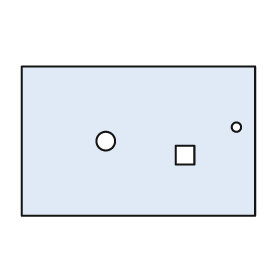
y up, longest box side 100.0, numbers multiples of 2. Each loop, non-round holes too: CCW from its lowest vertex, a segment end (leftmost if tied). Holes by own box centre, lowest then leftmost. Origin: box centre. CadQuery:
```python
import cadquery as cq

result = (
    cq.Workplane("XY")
    .moveTo(-50.0, -32.0)
    .lineTo(50.0, -32.0)
    .lineTo(50.0, 32.0)
    .lineTo(-50.0, 32.0)
    .close()
    .moveTo(16.0, -10.0)
    .lineTo(24.0, -10.0)
    .lineTo(24.0, -2.0)
    .lineTo(16.0, -2.0)
    .close()
    .moveTo(-14.0, 0.0)
    .circle(4.0)
    .moveTo(42.0, 6.0)
    .circle(2.0)
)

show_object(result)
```